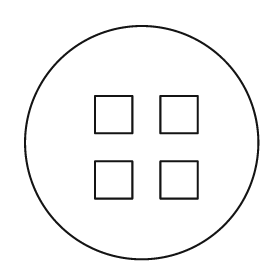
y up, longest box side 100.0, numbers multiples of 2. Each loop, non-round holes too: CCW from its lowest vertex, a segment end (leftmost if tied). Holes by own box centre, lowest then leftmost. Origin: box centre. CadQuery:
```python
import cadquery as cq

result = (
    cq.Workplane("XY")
    .moveTo(0.0, 0.0)
    .circle(50.0)
    .moveTo(-20.0, -24.0)
    .lineTo(-4.0, -24.0)
    .lineTo(-4.0, -8.0)
    .lineTo(-20.0, -8.0)
    .close()
    .moveTo(8.0, -24.0)
    .lineTo(24.0, -24.0)
    .lineTo(24.0, -8.0)
    .lineTo(8.0, -8.0)
    .close()
    .moveTo(-20.0, 4.0)
    .lineTo(-4.0, 4.0)
    .lineTo(-4.0, 20.0)
    .lineTo(-20.0, 20.0)
    .close()
    .moveTo(8.0, 4.0)
    .lineTo(24.0, 4.0)
    .lineTo(24.0, 20.0)
    .lineTo(8.0, 20.0)
    .close()
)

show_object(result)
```